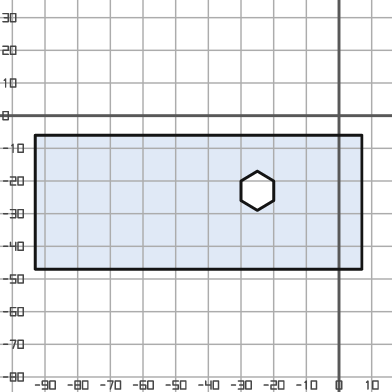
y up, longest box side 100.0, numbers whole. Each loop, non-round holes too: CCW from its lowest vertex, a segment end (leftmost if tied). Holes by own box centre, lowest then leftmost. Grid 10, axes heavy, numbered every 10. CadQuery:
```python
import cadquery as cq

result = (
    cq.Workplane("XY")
    .moveTo(-93.0, -47.0)
    .lineTo(7.0, -47.0)
    .lineTo(7.0, -6.0)
    .lineTo(-93.0, -6.0)
    .close()
    .moveTo(-25.0, -29.0)
    .lineTo(-20.0, -26.0)
    .lineTo(-20.0, -20.0)
    .lineTo(-25.0, -17.0)
    .lineTo(-30.0, -20.0)
    .lineTo(-30.0, -26.0)
    .close()
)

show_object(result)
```